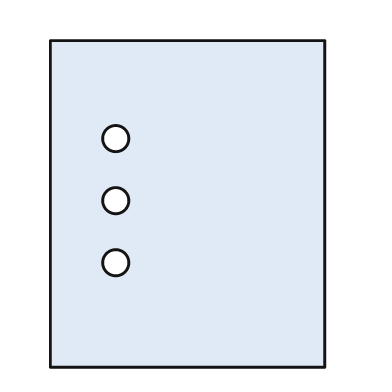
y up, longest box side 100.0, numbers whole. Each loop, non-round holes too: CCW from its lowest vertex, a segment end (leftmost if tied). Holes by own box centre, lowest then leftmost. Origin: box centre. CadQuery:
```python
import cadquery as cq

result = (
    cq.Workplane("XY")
    .moveTo(-42.0, -50.0)
    .lineTo(42.0, -50.0)
    .lineTo(42.0, 50.0)
    .lineTo(-42.0, 50.0)
    .close()
    .moveTo(-22.0, -18.0)
    .circle(4.0)
    .moveTo(-22.0, 1.0)
    .circle(4.0)
    .moveTo(-22.0, 20.0)
    .circle(4.0)
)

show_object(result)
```